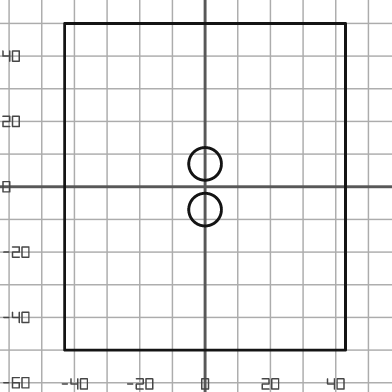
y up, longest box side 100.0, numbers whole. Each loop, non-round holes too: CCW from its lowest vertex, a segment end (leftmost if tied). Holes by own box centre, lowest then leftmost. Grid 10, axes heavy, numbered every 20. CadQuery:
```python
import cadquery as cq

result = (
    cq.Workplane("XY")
    .moveTo(-43.0, -50.0)
    .lineTo(43.0, -50.0)
    .lineTo(43.0, 50.0)
    .lineTo(-43.0, 50.0)
    .close()
    .moveTo(0.0, -7.0)
    .circle(5.0)
    .moveTo(0.0, 7.0)
    .circle(5.0)
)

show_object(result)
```